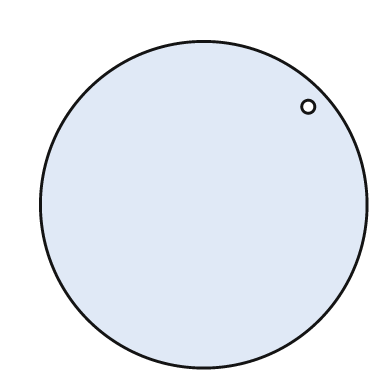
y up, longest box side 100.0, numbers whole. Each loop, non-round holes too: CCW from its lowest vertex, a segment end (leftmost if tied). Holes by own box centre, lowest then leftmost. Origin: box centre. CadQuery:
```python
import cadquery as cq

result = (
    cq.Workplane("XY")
    .moveTo(0.0, 0.0)
    .circle(50.0)
    .moveTo(32.0, 30.0)
    .circle(2.0)
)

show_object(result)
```